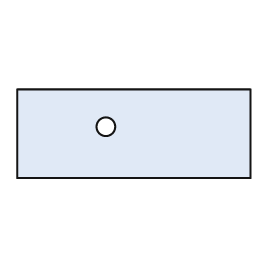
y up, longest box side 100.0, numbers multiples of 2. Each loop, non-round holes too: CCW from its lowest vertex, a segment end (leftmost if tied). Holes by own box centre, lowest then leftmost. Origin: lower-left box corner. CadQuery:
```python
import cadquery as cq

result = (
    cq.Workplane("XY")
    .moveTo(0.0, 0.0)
    .lineTo(100.0, 0.0)
    .lineTo(100.0, 38.0)
    .lineTo(0.0, 38.0)
    .close()
    .moveTo(38.0, 22.0)
    .circle(4.0)
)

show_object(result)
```